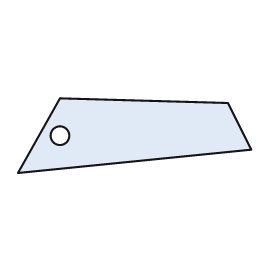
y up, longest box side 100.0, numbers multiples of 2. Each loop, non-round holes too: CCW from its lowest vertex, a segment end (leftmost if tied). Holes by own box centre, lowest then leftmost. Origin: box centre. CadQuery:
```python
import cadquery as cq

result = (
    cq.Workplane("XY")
    .moveTo(-50.0, -16.0)
    .lineTo(50.0, -6.0)
    .lineTo(40.0, 14.0)
    .lineTo(-32.0, 16.0)
    .close()
    .moveTo(-32.0, 0.0)
    .circle(4.0)
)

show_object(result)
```